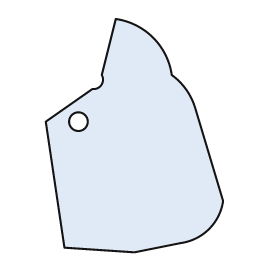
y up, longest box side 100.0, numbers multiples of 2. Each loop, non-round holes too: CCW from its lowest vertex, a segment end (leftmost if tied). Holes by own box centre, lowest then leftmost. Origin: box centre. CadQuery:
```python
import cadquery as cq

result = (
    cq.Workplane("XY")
    .moveTo(0.0, -50.0)
    .lineTo(20.0, -46.0)
    .threePointArc((32.0, -40.0), (38.0, -28.0))
    .lineTo(26.0, 12.0)
    .threePointArc((22.0, 20.0), (16.0, 26.0))
    .threePointArc((8.0, 42.0), (-8.0, 50.0))
    .lineTo(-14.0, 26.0)
    .threePointArc((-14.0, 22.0), (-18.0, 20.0))
    .lineTo(-38.0, 6.0)
    .lineTo(-30.0, -48.0)
    .close()
    .moveTo(-24.0, 6.0)
    .circle(4.0)
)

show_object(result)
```